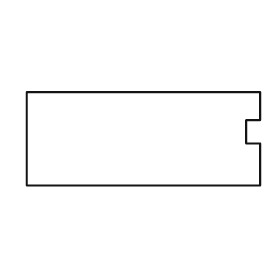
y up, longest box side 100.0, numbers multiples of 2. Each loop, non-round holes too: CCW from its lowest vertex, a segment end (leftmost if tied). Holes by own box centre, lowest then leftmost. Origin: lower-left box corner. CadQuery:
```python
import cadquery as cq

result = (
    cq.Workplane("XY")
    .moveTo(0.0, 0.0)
    .lineTo(100.0, 0.0)
    .lineTo(100.0, 18.0)
    .lineTo(94.0, 18.0)
    .lineTo(94.0, 28.0)
    .lineTo(100.0, 28.0)
    .lineTo(100.0, 40.0)
    .lineTo(0.0, 40.0)
    .close()
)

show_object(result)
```